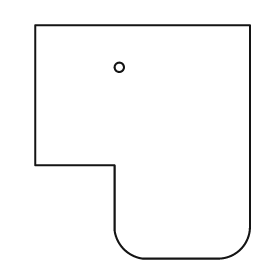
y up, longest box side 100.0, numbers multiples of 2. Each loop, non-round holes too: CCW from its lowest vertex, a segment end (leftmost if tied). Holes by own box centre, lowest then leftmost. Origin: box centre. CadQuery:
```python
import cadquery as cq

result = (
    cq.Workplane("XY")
    .moveTo(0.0, -50.0)
    .lineTo(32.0, -50.0)
    .threePointArc((42.0, -46.0), (46.0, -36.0))
    .lineTo(46.0, 50.0)
    .lineTo(-46.0, 50.0)
    .lineTo(-46.0, -10.0)
    .lineTo(-12.0, -10.0)
    .lineTo(-12.0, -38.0)
    .threePointArc((-8.0, -46.0), (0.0, -50.0))
    .close()
    .moveTo(-10.0, 32.0)
    .circle(2.0)
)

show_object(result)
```